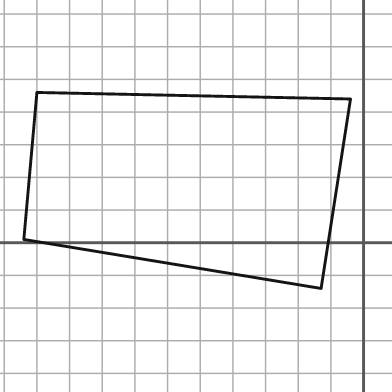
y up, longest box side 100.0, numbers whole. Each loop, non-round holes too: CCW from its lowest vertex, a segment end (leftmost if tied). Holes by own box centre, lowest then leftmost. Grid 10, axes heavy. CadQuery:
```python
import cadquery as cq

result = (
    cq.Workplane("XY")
    .moveTo(-13.0, -14.0)
    .lineTo(-4.0, 44.0)
    .lineTo(-100.0, 46.0)
    .lineTo(-104.0, 1.0)
    .close()
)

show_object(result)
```